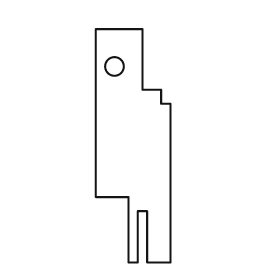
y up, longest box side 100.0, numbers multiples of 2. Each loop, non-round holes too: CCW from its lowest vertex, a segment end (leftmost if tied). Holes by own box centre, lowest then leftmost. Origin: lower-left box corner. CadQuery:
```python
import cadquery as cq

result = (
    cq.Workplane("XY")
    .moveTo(14.0, 0.0)
    .lineTo(18.0, 0.0)
    .lineTo(18.0, 22.0)
    .lineTo(22.0, 22.0)
    .lineTo(22.0, 0.0)
    .lineTo(32.0, 0.0)
    .lineTo(32.0, 68.0)
    .lineTo(28.0, 68.0)
    .lineTo(28.0, 74.0)
    .lineTo(20.0, 74.0)
    .lineTo(20.0, 100.0)
    .lineTo(0.0, 100.0)
    .lineTo(0.0, 28.0)
    .lineTo(14.0, 28.0)
    .close()
    .moveTo(8.0, 84.0)
    .circle(4.0)
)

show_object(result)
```